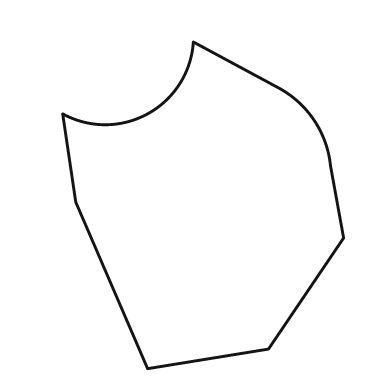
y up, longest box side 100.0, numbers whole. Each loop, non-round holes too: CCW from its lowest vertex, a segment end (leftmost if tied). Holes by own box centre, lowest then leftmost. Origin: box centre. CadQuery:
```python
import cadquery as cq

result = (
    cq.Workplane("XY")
    .moveTo(-17.0, -50.0)
    .lineTo(20.0, -44.0)
    .lineTo(43.0, -10.0)
    .lineTo(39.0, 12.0)
    .threePointArc((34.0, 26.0), (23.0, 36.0))
    .lineTo(-3.0, 50.0)
    .threePointArc((-17.0, 28.0), (-43.0, 28.0))
    .lineTo(-39.0, 1.0)
    .close()
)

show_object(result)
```